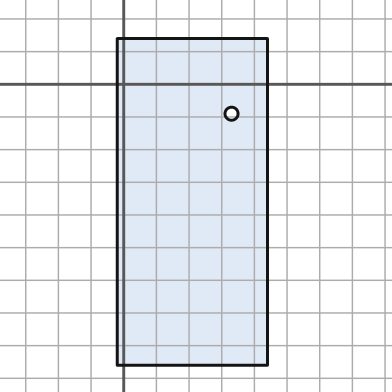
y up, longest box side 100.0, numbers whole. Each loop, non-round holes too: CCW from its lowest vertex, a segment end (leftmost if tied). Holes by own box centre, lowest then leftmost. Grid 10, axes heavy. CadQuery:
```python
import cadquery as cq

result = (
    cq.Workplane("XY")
    .moveTo(-2.0, -86.0)
    .lineTo(44.0, -86.0)
    .lineTo(44.0, 14.0)
    .lineTo(-2.0, 14.0)
    .close()
    .moveTo(33.0, -9.0)
    .circle(2.0)
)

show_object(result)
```